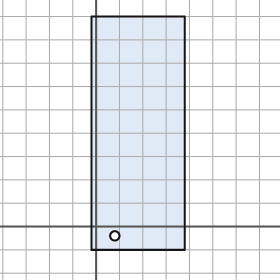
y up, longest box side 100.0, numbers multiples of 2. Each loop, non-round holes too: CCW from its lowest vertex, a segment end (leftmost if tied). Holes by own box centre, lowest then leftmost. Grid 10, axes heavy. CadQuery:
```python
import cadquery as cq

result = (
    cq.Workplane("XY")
    .moveTo(-2.0, -10.0)
    .lineTo(38.0, -10.0)
    .lineTo(38.0, 90.0)
    .lineTo(-2.0, 90.0)
    .close()
    .moveTo(8.0, -4.0)
    .circle(2.0)
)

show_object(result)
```